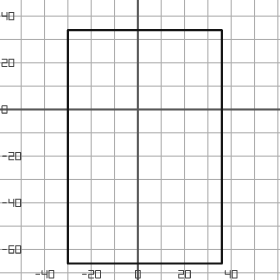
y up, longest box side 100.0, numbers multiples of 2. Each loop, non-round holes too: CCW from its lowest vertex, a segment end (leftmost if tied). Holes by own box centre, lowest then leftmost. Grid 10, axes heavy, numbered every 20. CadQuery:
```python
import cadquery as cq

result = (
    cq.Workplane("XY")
    .moveTo(-30.0, -66.0)
    .lineTo(36.0, -66.0)
    .lineTo(36.0, 34.0)
    .lineTo(-30.0, 34.0)
    .close()
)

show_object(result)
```